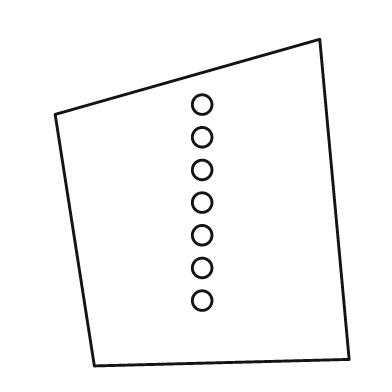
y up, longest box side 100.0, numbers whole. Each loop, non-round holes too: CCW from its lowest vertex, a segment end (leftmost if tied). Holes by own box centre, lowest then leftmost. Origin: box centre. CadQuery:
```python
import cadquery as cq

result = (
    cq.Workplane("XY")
    .moveTo(-33.0, -50.0)
    .lineTo(45.0, -48.0)
    .lineTo(36.0, 50.0)
    .lineTo(-45.0, 27.0)
    .close()
    .moveTo(0.0, -30.0)
    .circle(3.0)
    .moveTo(0.0, -20.0)
    .circle(3.0)
    .moveTo(0.0, -10.0)
    .circle(3.0)
    .moveTo(0.0, 0.0)
    .circle(3.0)
    .moveTo(0.0, 10.0)
    .circle(3.0)
    .moveTo(0.0, 20.0)
    .circle(3.0)
    .moveTo(0.0, 30.0)
    .circle(3.0)
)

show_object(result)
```